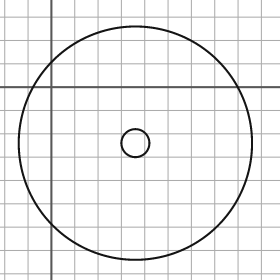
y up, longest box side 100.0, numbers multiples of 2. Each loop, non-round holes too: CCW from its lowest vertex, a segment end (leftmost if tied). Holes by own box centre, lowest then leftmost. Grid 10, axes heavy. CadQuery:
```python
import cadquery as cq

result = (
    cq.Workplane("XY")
    .moveTo(36.0, -24.0)
    .circle(50.0)
    .moveTo(36.0, -24.0)
    .circle(6.0)
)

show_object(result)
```